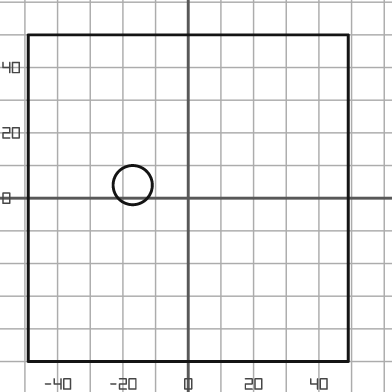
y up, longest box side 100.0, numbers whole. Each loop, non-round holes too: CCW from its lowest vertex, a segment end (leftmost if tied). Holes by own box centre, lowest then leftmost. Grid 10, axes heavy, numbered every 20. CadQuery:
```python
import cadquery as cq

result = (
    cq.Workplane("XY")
    .moveTo(-49.0, -50.0)
    .lineTo(49.0, -50.0)
    .lineTo(49.0, 50.0)
    .lineTo(-49.0, 50.0)
    .close()
    .moveTo(-17.0, 4.0)
    .circle(6.0)
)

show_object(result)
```